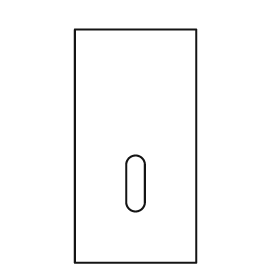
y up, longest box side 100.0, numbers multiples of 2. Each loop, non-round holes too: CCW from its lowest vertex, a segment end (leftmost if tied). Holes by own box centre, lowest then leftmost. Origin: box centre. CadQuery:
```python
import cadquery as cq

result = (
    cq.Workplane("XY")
    .moveTo(-26.0, -50.0)
    .lineTo(26.0, -50.0)
    .lineTo(26.0, 50.0)
    .lineTo(-26.0, 50.0)
    .close()
    .moveTo(-4.0, -24.0)
    .threePointArc((0.0, -28.0), (4.0, -24.0))
    .lineTo(4.0, -8.0)
    .threePointArc((0.0, -4.0), (-4.0, -8.0))
    .close()
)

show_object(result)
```